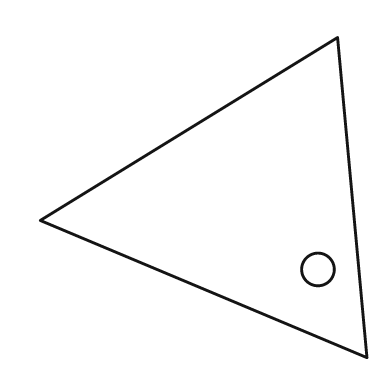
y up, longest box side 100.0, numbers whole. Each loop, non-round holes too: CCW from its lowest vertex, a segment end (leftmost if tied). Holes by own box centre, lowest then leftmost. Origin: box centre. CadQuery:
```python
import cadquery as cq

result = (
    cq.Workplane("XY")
    .moveTo(50.0, -49.0)
    .lineTo(41.0, 49.0)
    .lineTo(-50.0, -7.0)
    .close()
    .moveTo(35.0, -22.0)
    .circle(5.0)
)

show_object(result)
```